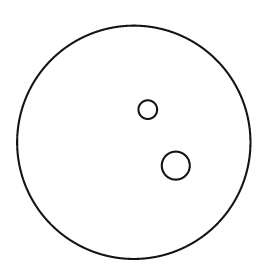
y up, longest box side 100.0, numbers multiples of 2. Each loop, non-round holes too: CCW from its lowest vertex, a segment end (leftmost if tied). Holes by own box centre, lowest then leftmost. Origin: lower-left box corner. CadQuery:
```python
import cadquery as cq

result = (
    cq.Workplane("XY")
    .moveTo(50.0, 50.0)
    .circle(50.0)
    .moveTo(68.0, 40.0)
    .circle(6.0)
    .moveTo(56.0, 64.0)
    .circle(4.0)
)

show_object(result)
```